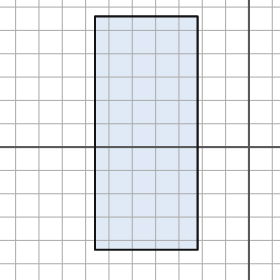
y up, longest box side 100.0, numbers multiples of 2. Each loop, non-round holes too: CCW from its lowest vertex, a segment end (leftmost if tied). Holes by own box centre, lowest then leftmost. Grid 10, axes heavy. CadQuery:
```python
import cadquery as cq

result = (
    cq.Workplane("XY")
    .moveTo(-66.0, -44.0)
    .lineTo(-22.0, -44.0)
    .lineTo(-22.0, 56.0)
    .lineTo(-66.0, 56.0)
    .close()
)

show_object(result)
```